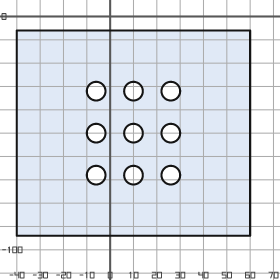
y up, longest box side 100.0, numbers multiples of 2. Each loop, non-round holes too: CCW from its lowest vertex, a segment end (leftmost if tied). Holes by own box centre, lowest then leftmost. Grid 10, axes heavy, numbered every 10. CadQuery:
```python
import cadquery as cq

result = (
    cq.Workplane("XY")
    .moveTo(-40.0, -94.0)
    .lineTo(60.0, -94.0)
    .lineTo(60.0, -6.0)
    .lineTo(-40.0, -6.0)
    .close()
    .moveTo(-6.0, -68.0)
    .circle(4.0)
    .moveTo(10.0, -68.0)
    .circle(4.0)
    .moveTo(26.0, -68.0)
    .circle(4.0)
    .moveTo(-6.0, -50.0)
    .circle(4.0)
    .moveTo(10.0, -50.0)
    .circle(4.0)
    .moveTo(26.0, -50.0)
    .circle(4.0)
    .moveTo(-6.0, -32.0)
    .circle(4.0)
    .moveTo(10.0, -32.0)
    .circle(4.0)
    .moveTo(26.0, -32.0)
    .circle(4.0)
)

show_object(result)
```